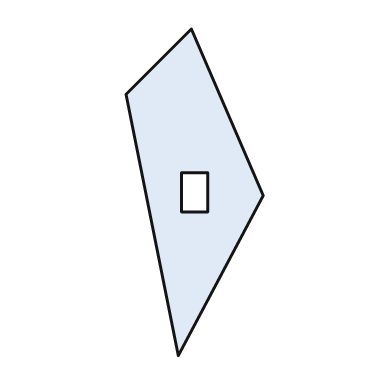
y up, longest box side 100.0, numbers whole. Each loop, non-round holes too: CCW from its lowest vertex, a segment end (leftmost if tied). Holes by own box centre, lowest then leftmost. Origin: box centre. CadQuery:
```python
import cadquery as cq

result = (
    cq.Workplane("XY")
    .moveTo(-5.0, -50.0)
    .lineTo(21.0, -1.0)
    .lineTo(-1.0, 50.0)
    .lineTo(-21.0, 30.0)
    .close()
    .moveTo(-4.0, -6.0)
    .lineTo(4.0, -6.0)
    .lineTo(4.0, 6.0)
    .lineTo(-4.0, 6.0)
    .close()
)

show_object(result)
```